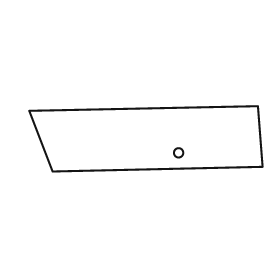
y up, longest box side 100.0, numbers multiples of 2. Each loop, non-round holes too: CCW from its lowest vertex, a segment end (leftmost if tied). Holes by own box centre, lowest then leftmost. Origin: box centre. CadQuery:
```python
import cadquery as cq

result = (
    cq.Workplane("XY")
    .moveTo(-40.0, -14.0)
    .lineTo(50.0, -12.0)
    .lineTo(48.0, 14.0)
    .lineTo(-50.0, 12.0)
    .close()
    .moveTo(14.0, -6.0)
    .circle(2.0)
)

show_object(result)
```